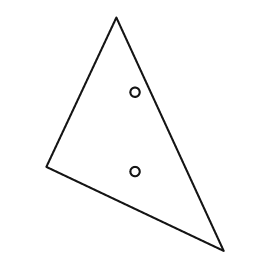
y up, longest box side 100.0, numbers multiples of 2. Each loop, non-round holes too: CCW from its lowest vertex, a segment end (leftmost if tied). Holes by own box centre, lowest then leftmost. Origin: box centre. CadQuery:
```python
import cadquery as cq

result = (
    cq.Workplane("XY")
    .moveTo(38.0, -50.0)
    .lineTo(-8.0, 50.0)
    .lineTo(-38.0, -14.0)
    .close()
    .moveTo(0.0, -16.0)
    .circle(2.0)
    .moveTo(0.0, 18.0)
    .circle(2.0)
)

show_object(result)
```